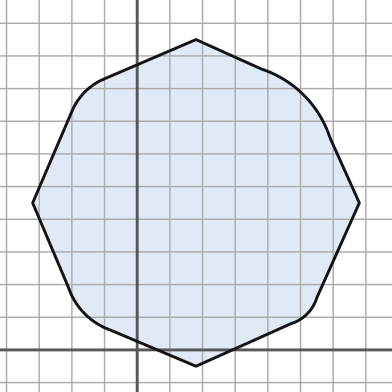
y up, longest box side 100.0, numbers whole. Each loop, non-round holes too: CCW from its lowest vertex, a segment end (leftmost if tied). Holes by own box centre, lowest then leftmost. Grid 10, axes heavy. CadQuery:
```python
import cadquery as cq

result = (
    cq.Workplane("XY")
    .moveTo(18.0, -5.0)
    .lineTo(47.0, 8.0)
    .threePointArc((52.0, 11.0), (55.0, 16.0))
    .lineTo(68.0, 45.0)
    .lineTo(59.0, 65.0)
    .threePointArc((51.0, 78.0), (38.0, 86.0))
    .lineTo(18.0, 95.0)
    .lineTo(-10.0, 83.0)
    .threePointArc((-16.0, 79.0), (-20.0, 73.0))
    .lineTo(-32.0, 45.0)
    .lineTo(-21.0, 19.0)
    .threePointArc((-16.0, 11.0), (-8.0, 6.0))
    .close()
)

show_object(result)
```